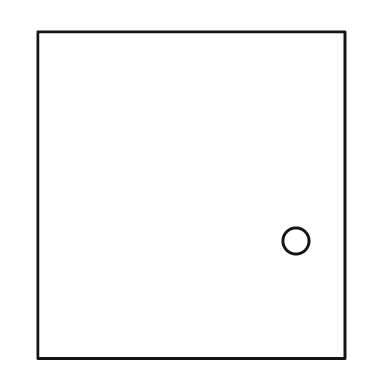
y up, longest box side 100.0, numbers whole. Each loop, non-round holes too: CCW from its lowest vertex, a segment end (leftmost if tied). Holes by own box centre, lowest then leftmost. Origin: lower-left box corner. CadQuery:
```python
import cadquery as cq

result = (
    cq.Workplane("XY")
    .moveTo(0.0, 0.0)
    .lineTo(94.0, 0.0)
    .lineTo(94.0, 100.0)
    .lineTo(0.0, 100.0)
    .close()
    .moveTo(79.0, 36.0)
    .circle(4.0)
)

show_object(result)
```